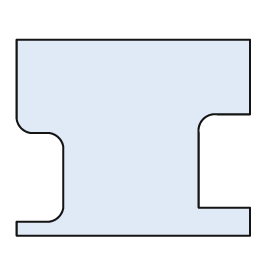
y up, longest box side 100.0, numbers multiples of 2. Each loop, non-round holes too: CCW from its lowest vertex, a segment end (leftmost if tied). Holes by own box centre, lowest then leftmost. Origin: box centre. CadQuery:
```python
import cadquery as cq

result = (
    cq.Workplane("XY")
    .moveTo(-50.0, -42.0)
    .lineTo(50.0, -42.0)
    .lineTo(50.0, -30.0)
    .lineTo(28.0, -30.0)
    .lineTo(28.0, 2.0)
    .threePointArc((30.0, 8.0), (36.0, 10.0))
    .lineTo(50.0, 10.0)
    .lineTo(50.0, 42.0)
    .lineTo(-50.0, 42.0)
    .lineTo(-50.0, 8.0)
    .threePointArc((-48.0, 4.0), (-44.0, 2.0))
    .lineTo(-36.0, 2.0)
    .threePointArc((-32.0, 0.0), (-30.0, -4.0))
    .lineTo(-30.0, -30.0)
    .threePointArc((-32.0, -34.0), (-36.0, -36.0))
    .lineTo(-50.0, -36.0)
    .close()
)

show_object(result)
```